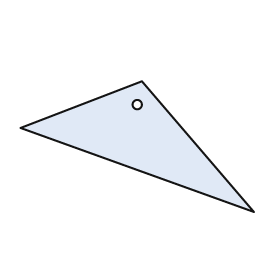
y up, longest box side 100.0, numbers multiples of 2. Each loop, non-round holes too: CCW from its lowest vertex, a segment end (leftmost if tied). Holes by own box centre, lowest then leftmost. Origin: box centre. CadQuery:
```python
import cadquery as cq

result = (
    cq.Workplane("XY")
    .moveTo(50.0, -28.0)
    .lineTo(2.0, 28.0)
    .lineTo(-50.0, 8.0)
    .close()
    .moveTo(0.0, 18.0)
    .circle(2.0)
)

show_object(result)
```